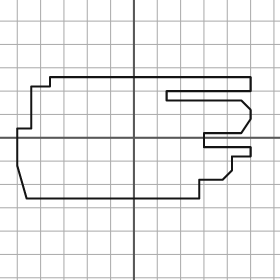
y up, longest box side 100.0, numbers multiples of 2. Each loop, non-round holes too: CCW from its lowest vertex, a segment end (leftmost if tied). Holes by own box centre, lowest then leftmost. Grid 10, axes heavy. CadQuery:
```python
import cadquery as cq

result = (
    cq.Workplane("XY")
    .moveTo(-46.0, -26.0)
    .lineTo(28.0, -26.0)
    .lineTo(28.0, -18.0)
    .lineTo(38.0, -18.0)
    .lineTo(42.0, -14.0)
    .lineTo(42.0, -8.0)
    .lineTo(50.0, -8.0)
    .lineTo(50.0, -4.0)
    .lineTo(30.0, -4.0)
    .lineTo(30.0, 2.0)
    .lineTo(46.0, 2.0)
    .lineTo(50.0, 8.0)
    .lineTo(50.0, 12.0)
    .lineTo(46.0, 16.0)
    .lineTo(14.0, 16.0)
    .lineTo(14.0, 20.0)
    .lineTo(50.0, 20.0)
    .lineTo(50.0, 26.0)
    .lineTo(-36.0, 26.0)
    .lineTo(-36.0, 22.0)
    .lineTo(-44.0, 22.0)
    .lineTo(-44.0, 4.0)
    .lineTo(-50.0, 4.0)
    .lineTo(-50.0, -12.0)
    .close()
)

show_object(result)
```